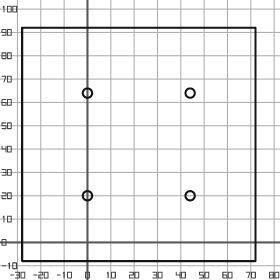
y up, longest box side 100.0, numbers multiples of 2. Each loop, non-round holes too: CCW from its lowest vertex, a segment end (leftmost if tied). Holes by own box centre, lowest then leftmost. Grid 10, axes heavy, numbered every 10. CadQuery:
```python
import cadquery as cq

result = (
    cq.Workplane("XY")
    .moveTo(-28.0, -8.0)
    .lineTo(72.0, -8.0)
    .lineTo(72.0, 92.0)
    .lineTo(-28.0, 92.0)
    .close()
    .moveTo(0.0, 20.0)
    .circle(2.0)
    .moveTo(44.0, 20.0)
    .circle(2.0)
    .moveTo(0.0, 64.0)
    .circle(2.0)
    .moveTo(44.0, 64.0)
    .circle(2.0)
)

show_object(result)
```